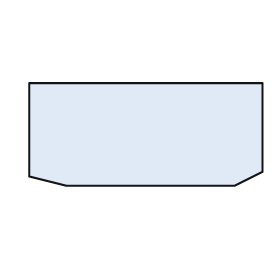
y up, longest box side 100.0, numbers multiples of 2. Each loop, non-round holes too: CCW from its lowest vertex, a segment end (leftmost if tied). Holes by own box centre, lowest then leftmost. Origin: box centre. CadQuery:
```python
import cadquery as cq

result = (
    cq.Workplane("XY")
    .moveTo(-34.0, -22.0)
    .lineTo(38.0, -22.0)
    .lineTo(50.0, -16.0)
    .lineTo(50.0, 22.0)
    .lineTo(-50.0, 22.0)
    .lineTo(-50.0, -18.0)
    .close()
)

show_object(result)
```